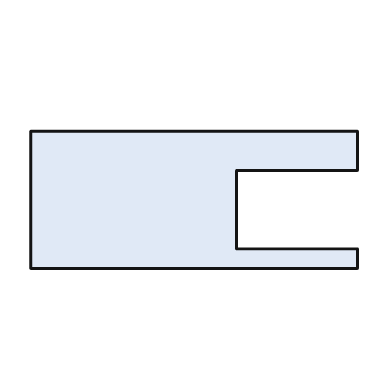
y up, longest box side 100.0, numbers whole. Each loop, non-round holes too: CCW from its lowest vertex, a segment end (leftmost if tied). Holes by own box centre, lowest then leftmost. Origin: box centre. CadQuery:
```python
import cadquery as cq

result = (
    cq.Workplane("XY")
    .moveTo(-50.0, -21.0)
    .lineTo(50.0, -21.0)
    .lineTo(50.0, -15.0)
    .lineTo(13.0, -15.0)
    .lineTo(13.0, 9.0)
    .lineTo(50.0, 9.0)
    .lineTo(50.0, 21.0)
    .lineTo(-50.0, 21.0)
    .close()
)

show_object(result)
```